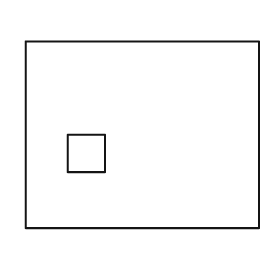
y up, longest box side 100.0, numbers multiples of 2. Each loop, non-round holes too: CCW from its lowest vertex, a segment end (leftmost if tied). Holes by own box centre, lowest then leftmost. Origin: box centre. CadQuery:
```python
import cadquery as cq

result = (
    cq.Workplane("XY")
    .moveTo(-50.0, -40.0)
    .lineTo(50.0, -40.0)
    .lineTo(50.0, 40.0)
    .lineTo(-50.0, 40.0)
    .close()
    .moveTo(-32.0, -16.0)
    .lineTo(-16.0, -16.0)
    .lineTo(-16.0, 0.0)
    .lineTo(-32.0, 0.0)
    .close()
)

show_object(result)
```